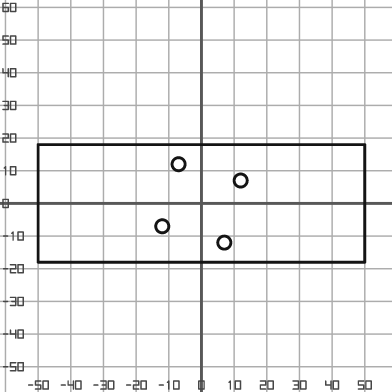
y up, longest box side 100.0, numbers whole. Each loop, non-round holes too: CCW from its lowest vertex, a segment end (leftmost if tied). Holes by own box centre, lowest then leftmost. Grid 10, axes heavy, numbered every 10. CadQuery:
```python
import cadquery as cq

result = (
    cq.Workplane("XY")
    .moveTo(-50.0, -18.0)
    .lineTo(50.0, -18.0)
    .lineTo(50.0, 18.0)
    .lineTo(-50.0, 18.0)
    .close()
    .moveTo(7.0, -12.0)
    .circle(2.0)
    .moveTo(-12.0, -7.0)
    .circle(2.0)
    .moveTo(12.0, 7.0)
    .circle(2.0)
    .moveTo(-7.0, 12.0)
    .circle(2.0)
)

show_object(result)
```